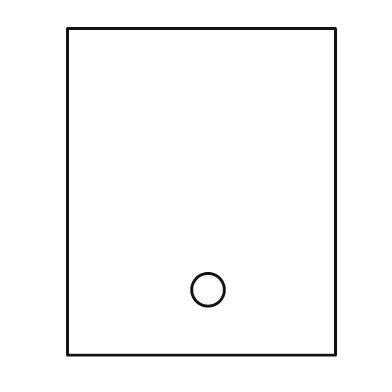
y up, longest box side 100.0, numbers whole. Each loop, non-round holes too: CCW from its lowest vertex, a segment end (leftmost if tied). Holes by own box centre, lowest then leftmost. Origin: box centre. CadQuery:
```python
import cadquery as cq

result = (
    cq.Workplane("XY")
    .moveTo(-41.0, -50.0)
    .lineTo(41.0, -50.0)
    .lineTo(41.0, 50.0)
    .lineTo(-41.0, 50.0)
    .close()
    .moveTo(2.0, -30.0)
    .circle(5.0)
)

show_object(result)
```